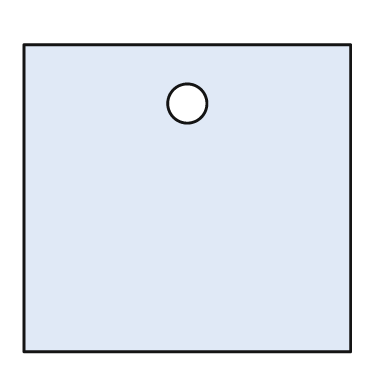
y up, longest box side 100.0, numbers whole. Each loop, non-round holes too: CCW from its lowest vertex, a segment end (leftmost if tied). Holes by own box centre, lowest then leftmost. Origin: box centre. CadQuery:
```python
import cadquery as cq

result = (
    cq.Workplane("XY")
    .moveTo(-50.0, -47.0)
    .lineTo(50.0, -47.0)
    .lineTo(50.0, 47.0)
    .lineTo(-50.0, 47.0)
    .close()
    .moveTo(0.0, 29.0)
    .circle(6.0)
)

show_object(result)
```